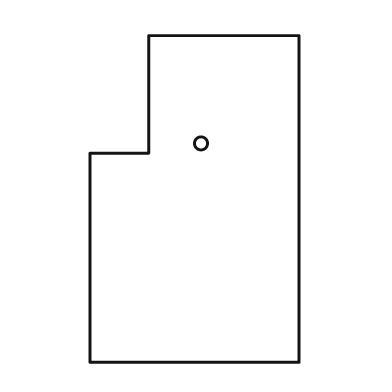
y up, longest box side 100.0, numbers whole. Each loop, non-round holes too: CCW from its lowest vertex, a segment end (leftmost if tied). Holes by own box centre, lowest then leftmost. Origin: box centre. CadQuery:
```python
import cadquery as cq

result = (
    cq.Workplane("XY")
    .moveTo(-32.0, -50.0)
    .lineTo(32.0, -50.0)
    .lineTo(32.0, 50.0)
    .lineTo(-14.0, 50.0)
    .lineTo(-14.0, 14.0)
    .lineTo(-32.0, 14.0)
    .close()
    .moveTo(2.0, 17.0)
    .circle(2.0)
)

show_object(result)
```